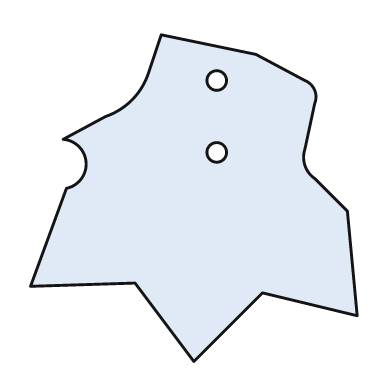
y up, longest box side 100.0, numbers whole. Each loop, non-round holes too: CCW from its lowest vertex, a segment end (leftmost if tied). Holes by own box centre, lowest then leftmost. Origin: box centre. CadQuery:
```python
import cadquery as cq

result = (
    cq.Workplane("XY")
    .moveTo(0.0, -50.0)
    .lineTo(21.0, -29.0)
    .lineTo(50.0, -36.0)
    .lineTo(47.0, -4.0)
    .lineTo(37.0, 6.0)
    .threePointArc((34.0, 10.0), (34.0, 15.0))
    .lineTo(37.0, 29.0)
    .threePointArc((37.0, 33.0), (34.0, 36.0))
    .lineTo(19.0, 44.0)
    .lineTo(-10.0, 50.0)
    .lineTo(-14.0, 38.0)
    .threePointArc((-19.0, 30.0), (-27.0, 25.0))
    .lineTo(-40.0, 18.0)
    .threePointArc((-33.0, 11.0), (-39.0, 3.0))
    .lineTo(-50.0, -27.0)
    .lineTo(-18.0, -26.0)
    .close()
    .moveTo(7.0, 14.0)
    .circle(3.0)
    .moveTo(7.0, 36.0)
    .circle(3.0)
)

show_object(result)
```